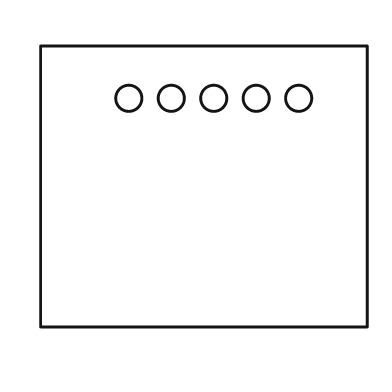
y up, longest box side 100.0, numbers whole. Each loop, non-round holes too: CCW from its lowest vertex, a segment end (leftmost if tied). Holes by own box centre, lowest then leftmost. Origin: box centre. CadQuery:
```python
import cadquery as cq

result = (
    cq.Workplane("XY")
    .moveTo(-50.0, -43.0)
    .lineTo(50.0, -43.0)
    .lineTo(50.0, 43.0)
    .lineTo(-50.0, 43.0)
    .close()
    .moveTo(-23.0, 27.0)
    .circle(4.0)
    .moveTo(-10.0, 27.0)
    .circle(4.0)
    .moveTo(3.0, 27.0)
    .circle(4.0)
    .moveTo(16.0, 27.0)
    .circle(4.0)
    .moveTo(29.0, 27.0)
    .circle(4.0)
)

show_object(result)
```